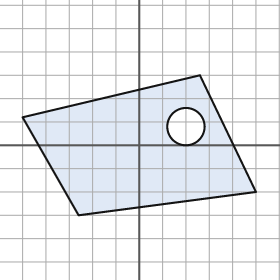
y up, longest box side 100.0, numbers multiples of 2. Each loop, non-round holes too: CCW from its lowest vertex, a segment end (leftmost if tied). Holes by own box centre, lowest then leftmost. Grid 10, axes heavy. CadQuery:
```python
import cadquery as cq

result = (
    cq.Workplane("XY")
    .moveTo(-26.0, -30.0)
    .lineTo(50.0, -20.0)
    .lineTo(26.0, 30.0)
    .lineTo(-50.0, 12.0)
    .close()
    .moveTo(20.0, 8.0)
    .circle(8.0)
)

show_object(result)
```